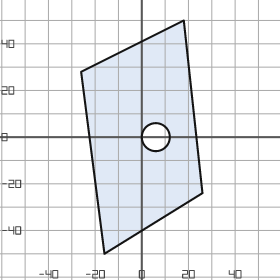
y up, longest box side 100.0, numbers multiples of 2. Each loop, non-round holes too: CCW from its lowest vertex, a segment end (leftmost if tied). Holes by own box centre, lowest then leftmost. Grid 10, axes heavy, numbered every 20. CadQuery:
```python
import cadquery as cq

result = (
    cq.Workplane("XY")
    .moveTo(-16.0, -50.0)
    .lineTo(26.0, -24.0)
    .lineTo(18.0, 50.0)
    .lineTo(-26.0, 28.0)
    .close()
    .moveTo(6.0, 0.0)
    .circle(6.0)
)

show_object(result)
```